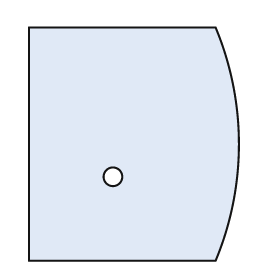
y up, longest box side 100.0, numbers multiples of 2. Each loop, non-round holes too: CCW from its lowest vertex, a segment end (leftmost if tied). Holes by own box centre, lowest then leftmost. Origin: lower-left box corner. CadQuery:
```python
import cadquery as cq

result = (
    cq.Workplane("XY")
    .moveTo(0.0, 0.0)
    .lineTo(80.0, 0.0)
    .threePointArc((90.0, 50.0), (80.0, 100.0))
    .lineTo(0.0, 100.0)
    .close()
    .moveTo(36.0, 36.0)
    .circle(4.0)
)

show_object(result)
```